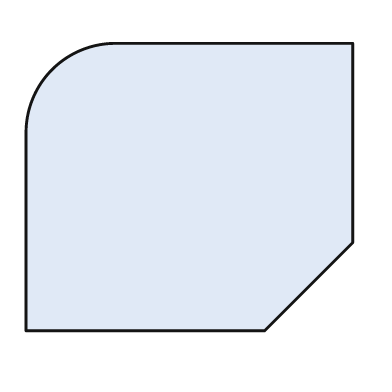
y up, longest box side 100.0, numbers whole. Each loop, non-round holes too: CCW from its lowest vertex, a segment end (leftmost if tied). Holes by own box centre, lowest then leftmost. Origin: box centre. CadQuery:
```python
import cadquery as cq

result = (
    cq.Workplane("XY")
    .moveTo(-50.0, -44.0)
    .lineTo(23.0, -44.0)
    .lineTo(50.0, -17.0)
    .lineTo(50.0, 44.0)
    .lineTo(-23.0, 44.0)
    .threePointArc((-42.0, 36.0), (-50.0, 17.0))
    .close()
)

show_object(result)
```